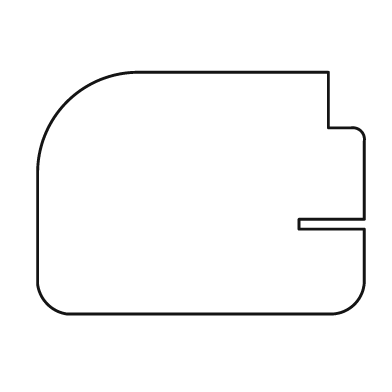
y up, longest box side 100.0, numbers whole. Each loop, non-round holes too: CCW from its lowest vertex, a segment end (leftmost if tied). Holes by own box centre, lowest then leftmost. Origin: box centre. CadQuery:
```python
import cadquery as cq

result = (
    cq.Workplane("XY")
    .moveTo(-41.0, -37.0)
    .lineTo(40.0, -37.0)
    .threePointArc((47.0, -34.0), (50.0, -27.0))
    .lineTo(50.0, -11.0)
    .lineTo(30.0, -11.0)
    .lineTo(30.0, -8.0)
    .lineTo(50.0, -8.0)
    .lineTo(50.0, 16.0)
    .threePointArc((49.0, 19.0), (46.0, 20.0))
    .lineTo(39.0, 20.0)
    .lineTo(39.0, 37.0)
    .lineTo(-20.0, 37.0)
    .threePointArc((-41.0, 28.0), (-50.0, 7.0))
    .lineTo(-50.0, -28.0)
    .threePointArc((-47.0, -34.0), (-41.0, -37.0))
    .close()
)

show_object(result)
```